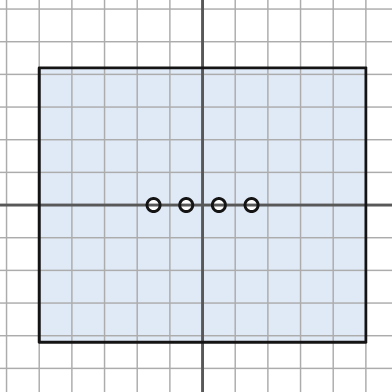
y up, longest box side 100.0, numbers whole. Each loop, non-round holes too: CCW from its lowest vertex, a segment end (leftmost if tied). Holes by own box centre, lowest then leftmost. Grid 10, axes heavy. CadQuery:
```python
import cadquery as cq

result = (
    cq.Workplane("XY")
    .moveTo(-50.0, -42.0)
    .lineTo(50.0, -42.0)
    .lineTo(50.0, 42.0)
    .lineTo(-50.0, 42.0)
    .close()
    .moveTo(-15.0, 0.0)
    .circle(2.0)
    .moveTo(-5.0, 0.0)
    .circle(2.0)
    .moveTo(5.0, 0.0)
    .circle(2.0)
    .moveTo(15.0, 0.0)
    .circle(2.0)
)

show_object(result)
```